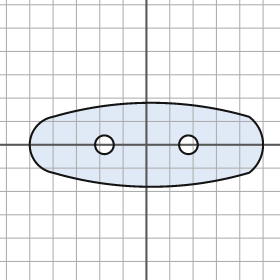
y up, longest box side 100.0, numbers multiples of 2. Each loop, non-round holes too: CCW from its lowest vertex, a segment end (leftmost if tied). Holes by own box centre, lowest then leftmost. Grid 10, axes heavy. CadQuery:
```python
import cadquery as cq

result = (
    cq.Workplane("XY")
    .moveTo(-40.0, -12.0)
    .threePointArc((2.0, -18.0), (44.0, -12.0))
    .threePointArc((50.0, 0.0), (44.0, 12.0))
    .threePointArc((2.0, 18.0), (-40.0, 12.0))
    .threePointArc((-50.0, 0.0), (-40.0, -12.0))
    .close()
    .moveTo(-18.0, 0.0)
    .circle(4.0)
    .moveTo(18.0, 0.0)
    .circle(4.0)
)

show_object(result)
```